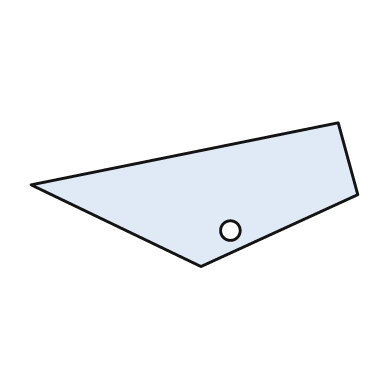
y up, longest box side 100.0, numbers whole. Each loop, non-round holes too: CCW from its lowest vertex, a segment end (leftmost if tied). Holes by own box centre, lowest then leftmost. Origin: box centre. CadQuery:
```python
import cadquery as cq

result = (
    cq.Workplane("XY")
    .moveTo(2.0, -22.0)
    .lineTo(50.0, 0.0)
    .lineTo(44.0, 22.0)
    .lineTo(-50.0, 3.0)
    .close()
    .moveTo(11.0, -11.0)
    .circle(3.0)
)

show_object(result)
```